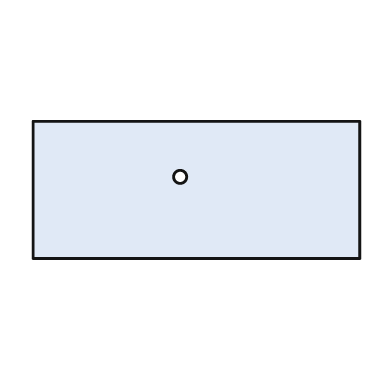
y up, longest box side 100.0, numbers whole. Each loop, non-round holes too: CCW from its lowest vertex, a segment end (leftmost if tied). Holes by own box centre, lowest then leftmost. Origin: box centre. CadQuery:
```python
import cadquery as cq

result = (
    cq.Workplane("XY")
    .moveTo(-50.0, -21.0)
    .lineTo(50.0, -21.0)
    .lineTo(50.0, 21.0)
    .lineTo(-50.0, 21.0)
    .close()
    .moveTo(-5.0, 4.0)
    .circle(2.0)
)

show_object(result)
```